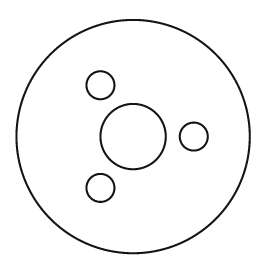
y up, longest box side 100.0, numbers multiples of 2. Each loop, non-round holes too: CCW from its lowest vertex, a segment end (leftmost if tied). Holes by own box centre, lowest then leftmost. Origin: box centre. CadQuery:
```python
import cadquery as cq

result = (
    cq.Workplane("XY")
    .moveTo(0.0, 0.0)
    .circle(50.0)
    .moveTo(-14.0, -22.0)
    .circle(6.0)
    .moveTo(0.0, 0.0)
    .circle(14.0)
    .moveTo(26.0, 0.0)
    .circle(6.0)
    .moveTo(-14.0, 22.0)
    .circle(6.0)
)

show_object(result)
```